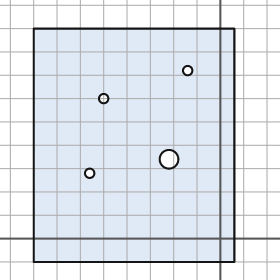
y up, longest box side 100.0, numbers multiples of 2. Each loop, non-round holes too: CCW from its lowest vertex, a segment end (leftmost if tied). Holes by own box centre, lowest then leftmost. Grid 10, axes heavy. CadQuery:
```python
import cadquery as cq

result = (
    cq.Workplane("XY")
    .moveTo(-80.0, -10.0)
    .lineTo(6.0, -10.0)
    .lineTo(6.0, 90.0)
    .lineTo(-80.0, 90.0)
    .close()
    .moveTo(-56.0, 28.0)
    .circle(2.0)
    .moveTo(-22.0, 34.0)
    .circle(4.0)
    .moveTo(-50.0, 60.0)
    .circle(2.0)
    .moveTo(-14.0, 72.0)
    .circle(2.0)
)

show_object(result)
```